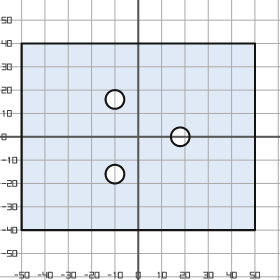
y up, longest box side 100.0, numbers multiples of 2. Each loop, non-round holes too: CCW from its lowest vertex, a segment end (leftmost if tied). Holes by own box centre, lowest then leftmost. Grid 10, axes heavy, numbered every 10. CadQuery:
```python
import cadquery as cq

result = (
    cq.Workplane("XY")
    .moveTo(-50.0, -40.0)
    .lineTo(50.0, -40.0)
    .lineTo(50.0, 40.0)
    .lineTo(-50.0, 40.0)
    .close()
    .moveTo(-10.0, -16.0)
    .circle(4.0)
    .moveTo(18.0, 0.0)
    .circle(4.0)
    .moveTo(-10.0, 16.0)
    .circle(4.0)
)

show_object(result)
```